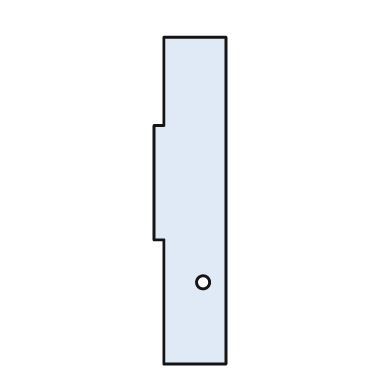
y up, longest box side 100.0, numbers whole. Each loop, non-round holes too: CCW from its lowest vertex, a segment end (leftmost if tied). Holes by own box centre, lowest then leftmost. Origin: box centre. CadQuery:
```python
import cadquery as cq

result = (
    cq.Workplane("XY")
    .moveTo(-8.0, -50.0)
    .lineTo(11.0, -50.0)
    .lineTo(11.0, 50.0)
    .lineTo(-8.0, 50.0)
    .lineTo(-8.0, 23.0)
    .lineTo(-11.0, 23.0)
    .lineTo(-11.0, -12.0)
    .lineTo(-8.0, -12.0)
    .close()
    .moveTo(4.0, -25.0)
    .circle(2.0)
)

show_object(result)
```